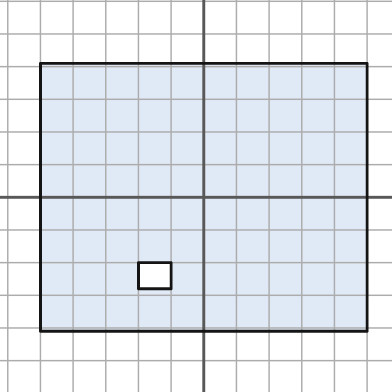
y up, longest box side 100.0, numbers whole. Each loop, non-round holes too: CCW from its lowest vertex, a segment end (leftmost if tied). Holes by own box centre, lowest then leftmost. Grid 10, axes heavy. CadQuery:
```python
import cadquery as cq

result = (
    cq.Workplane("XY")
    .moveTo(-50.0, -41.0)
    .lineTo(50.0, -41.0)
    .lineTo(50.0, 41.0)
    .lineTo(-50.0, 41.0)
    .close()
    .moveTo(-20.0, -28.0)
    .lineTo(-10.0, -28.0)
    .lineTo(-10.0, -20.0)
    .lineTo(-20.0, -20.0)
    .close()
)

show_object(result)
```